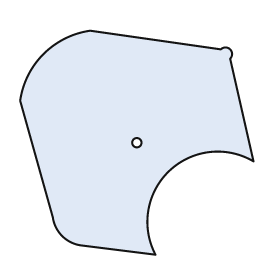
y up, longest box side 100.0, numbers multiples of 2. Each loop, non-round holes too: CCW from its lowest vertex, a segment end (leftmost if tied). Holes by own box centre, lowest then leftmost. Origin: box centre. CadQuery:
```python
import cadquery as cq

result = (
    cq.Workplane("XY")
    .moveTo(8.0, -48.0)
    .threePointArc((14.0, -12.0), (50.0, -8.0))
    .lineTo(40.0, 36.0)
    .threePointArc((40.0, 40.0), (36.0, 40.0))
    .lineTo(-20.0, 48.0)
    .threePointArc((-40.0, 38.0), (-50.0, 18.0))
    .lineTo(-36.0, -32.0)
    .threePointArc((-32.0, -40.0), (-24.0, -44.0))
    .close()
    .moveTo(0.0, 0.0)
    .circle(2.0)
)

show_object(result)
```